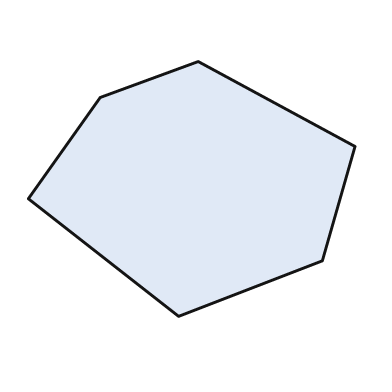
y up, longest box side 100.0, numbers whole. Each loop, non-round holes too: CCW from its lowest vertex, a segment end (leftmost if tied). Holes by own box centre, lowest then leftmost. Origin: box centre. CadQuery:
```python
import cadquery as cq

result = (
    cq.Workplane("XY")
    .moveTo(-4.0, -39.0)
    .lineTo(40.0, -22.0)
    .lineTo(50.0, 13.0)
    .lineTo(2.0, 39.0)
    .lineTo(-28.0, 28.0)
    .lineTo(-50.0, -3.0)
    .close()
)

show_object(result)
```